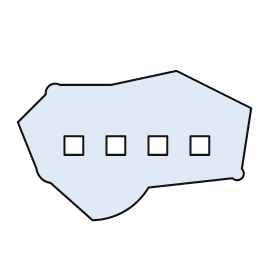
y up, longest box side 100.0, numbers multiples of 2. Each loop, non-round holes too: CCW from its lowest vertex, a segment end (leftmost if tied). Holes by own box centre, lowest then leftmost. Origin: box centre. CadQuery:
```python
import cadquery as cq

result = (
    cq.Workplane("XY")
    .moveTo(-18.0, -32.0)
    .threePointArc((-4.0, -28.0), (6.0, -18.0))
    .lineTo(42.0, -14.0)
    .threePointArc((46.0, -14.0), (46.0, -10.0))
    .lineTo(50.0, 16.0)
    .lineTo(18.0, 32.0)
    .lineTo(-10.0, 26.0)
    .lineTo(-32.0, 26.0)
    .threePointArc((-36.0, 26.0), (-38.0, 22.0))
    .lineTo(-50.0, 10.0)
    .lineTo(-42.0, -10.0)
    .threePointArc((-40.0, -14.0), (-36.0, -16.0))
    .close()
    .moveTo(-30.0, -4.0)
    .lineTo(-22.0, -4.0)
    .lineTo(-22.0, 4.0)
    .lineTo(-30.0, 4.0)
    .close()
    .moveTo(-12.0, -4.0)
    .lineTo(-4.0, -4.0)
    .lineTo(-4.0, 4.0)
    .lineTo(-12.0, 4.0)
    .close()
    .moveTo(6.0, -4.0)
    .lineTo(14.0, -4.0)
    .lineTo(14.0, 4.0)
    .lineTo(6.0, 4.0)
    .close()
    .moveTo(24.0, -4.0)
    .lineTo(32.0, -4.0)
    .lineTo(32.0, 4.0)
    .lineTo(24.0, 4.0)
    .close()
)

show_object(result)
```